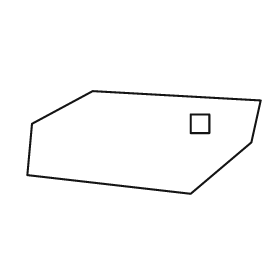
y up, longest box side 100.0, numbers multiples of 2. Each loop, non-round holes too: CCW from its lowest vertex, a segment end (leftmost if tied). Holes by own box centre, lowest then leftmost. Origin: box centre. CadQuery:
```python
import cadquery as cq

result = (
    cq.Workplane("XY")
    .moveTo(20.0, -22.0)
    .lineTo(46.0, 0.0)
    .lineTo(50.0, 18.0)
    .lineTo(-22.0, 22.0)
    .lineTo(-48.0, 8.0)
    .lineTo(-50.0, -14.0)
    .close()
    .moveTo(20.0, 4.0)
    .lineTo(28.0, 4.0)
    .lineTo(28.0, 12.0)
    .lineTo(20.0, 12.0)
    .close()
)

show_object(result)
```